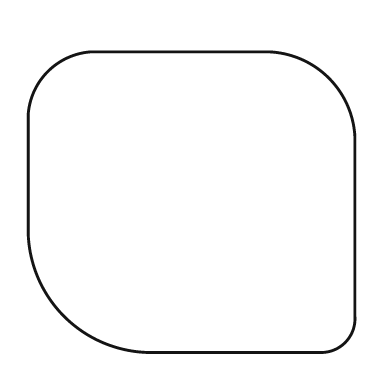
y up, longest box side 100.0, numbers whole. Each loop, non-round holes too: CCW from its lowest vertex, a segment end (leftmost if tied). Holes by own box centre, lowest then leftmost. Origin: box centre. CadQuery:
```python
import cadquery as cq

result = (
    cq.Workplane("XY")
    .moveTo(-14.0, -46.0)
    .lineTo(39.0, -46.0)
    .threePointArc((47.0, -43.0), (50.0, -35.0))
    .lineTo(50.0, 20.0)
    .threePointArc((42.0, 38.0), (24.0, 46.0))
    .lineTo(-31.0, 46.0)
    .threePointArc((-44.0, 40.0), (-50.0, 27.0))
    .lineTo(-50.0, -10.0)
    .threePointArc((-39.0, -35.0), (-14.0, -46.0))
    .close()
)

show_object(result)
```